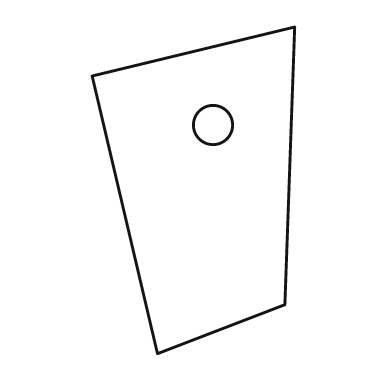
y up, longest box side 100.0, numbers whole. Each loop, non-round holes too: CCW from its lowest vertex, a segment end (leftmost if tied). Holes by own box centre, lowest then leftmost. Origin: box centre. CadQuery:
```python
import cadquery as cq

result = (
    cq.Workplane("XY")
    .moveTo(-11.0, -50.0)
    .lineTo(28.0, -35.0)
    .lineTo(31.0, 50.0)
    .lineTo(-31.0, 35.0)
    .close()
    .moveTo(6.0, 20.0)
    .circle(6.0)
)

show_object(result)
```